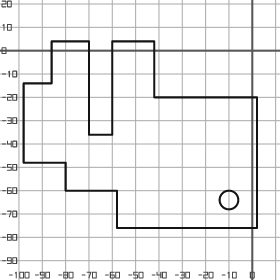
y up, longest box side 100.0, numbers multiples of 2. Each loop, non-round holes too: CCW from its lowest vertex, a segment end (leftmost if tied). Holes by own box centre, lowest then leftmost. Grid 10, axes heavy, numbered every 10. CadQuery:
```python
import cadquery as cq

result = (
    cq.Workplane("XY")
    .moveTo(-58.0, -76.0)
    .lineTo(2.0, -76.0)
    .lineTo(2.0, -20.0)
    .lineTo(-42.0, -20.0)
    .lineTo(-42.0, 4.0)
    .lineTo(-60.0, 4.0)
    .lineTo(-60.0, -36.0)
    .lineTo(-70.0, -36.0)
    .lineTo(-70.0, 4.0)
    .lineTo(-86.0, 4.0)
    .lineTo(-86.0, -14.0)
    .lineTo(-98.0, -14.0)
    .lineTo(-98.0, -48.0)
    .lineTo(-80.0, -48.0)
    .lineTo(-80.0, -60.0)
    .lineTo(-58.0, -60.0)
    .close()
    .moveTo(-10.0, -64.0)
    .circle(4.0)
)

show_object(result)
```